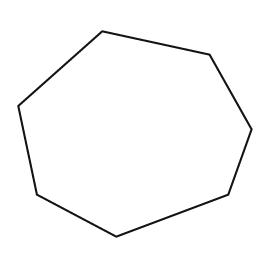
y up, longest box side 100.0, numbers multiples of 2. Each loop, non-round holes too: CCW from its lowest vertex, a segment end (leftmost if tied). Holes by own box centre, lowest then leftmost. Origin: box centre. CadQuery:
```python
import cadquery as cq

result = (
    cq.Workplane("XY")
    .moveTo(-8.0, -44.0)
    .lineTo(40.0, -26.0)
    .lineTo(50.0, 2.0)
    .lineTo(32.0, 34.0)
    .lineTo(-14.0, 44.0)
    .lineTo(-50.0, 12.0)
    .lineTo(-42.0, -26.0)
    .close()
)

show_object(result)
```